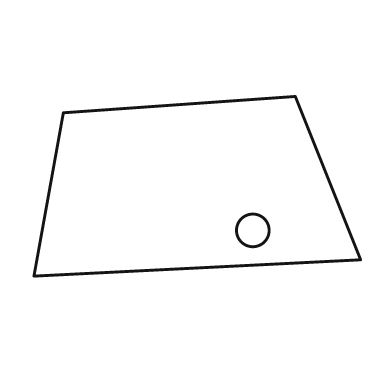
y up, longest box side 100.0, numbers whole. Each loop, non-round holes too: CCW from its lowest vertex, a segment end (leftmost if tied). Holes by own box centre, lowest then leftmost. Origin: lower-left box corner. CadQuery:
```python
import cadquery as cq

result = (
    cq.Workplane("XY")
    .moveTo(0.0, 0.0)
    .lineTo(100.0, 5.0)
    .lineTo(80.0, 55.0)
    .lineTo(9.0, 50.0)
    .close()
    .moveTo(67.0, 14.0)
    .circle(5.0)
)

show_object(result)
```